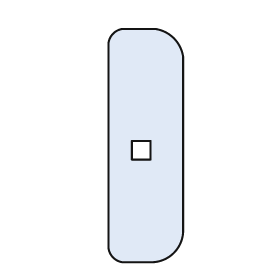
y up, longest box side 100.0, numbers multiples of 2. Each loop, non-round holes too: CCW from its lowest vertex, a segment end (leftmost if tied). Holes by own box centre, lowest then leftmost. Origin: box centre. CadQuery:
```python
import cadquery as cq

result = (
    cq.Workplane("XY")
    .moveTo(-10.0, -50.0)
    .lineTo(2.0, -50.0)
    .threePointArc((12.0, -46.0), (16.0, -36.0))
    .lineTo(16.0, 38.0)
    .threePointArc((12.0, 46.0), (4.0, 50.0))
    .lineTo(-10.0, 50.0)
    .threePointArc((-14.0, 48.0), (-16.0, 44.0))
    .lineTo(-16.0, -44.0)
    .threePointArc((-14.0, -48.0), (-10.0, -50.0))
    .close()
    .moveTo(-6.0, -6.0)
    .lineTo(2.0, -6.0)
    .lineTo(2.0, 2.0)
    .lineTo(-6.0, 2.0)
    .close()
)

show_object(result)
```